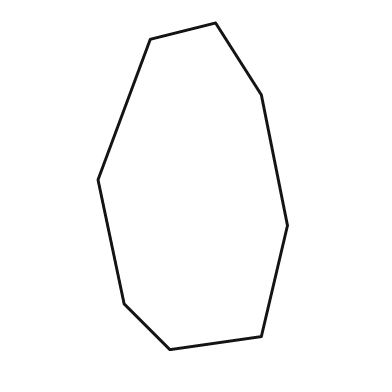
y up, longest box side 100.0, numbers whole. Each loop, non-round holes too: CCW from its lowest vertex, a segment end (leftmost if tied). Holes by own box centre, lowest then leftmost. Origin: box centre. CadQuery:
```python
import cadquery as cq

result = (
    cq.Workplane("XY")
    .moveTo(-7.0, -50.0)
    .lineTo(21.0, -46.0)
    .lineTo(29.0, -12.0)
    .lineTo(21.0, 28.0)
    .lineTo(7.0, 50.0)
    .lineTo(-13.0, 45.0)
    .lineTo(-29.0, 2.0)
    .lineTo(-21.0, -36.0)
    .close()
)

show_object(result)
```